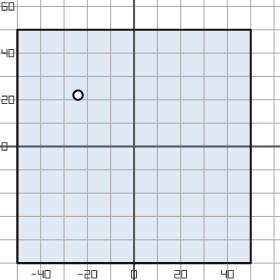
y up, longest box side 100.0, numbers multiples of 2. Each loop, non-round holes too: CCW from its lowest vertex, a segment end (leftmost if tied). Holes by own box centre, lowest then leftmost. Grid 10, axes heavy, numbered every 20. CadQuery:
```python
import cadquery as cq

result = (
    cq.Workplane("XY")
    .moveTo(-50.0, -50.0)
    .lineTo(50.0, -50.0)
    .lineTo(50.0, 50.0)
    .lineTo(-50.0, 50.0)
    .close()
    .moveTo(-24.0, 22.0)
    .circle(2.0)
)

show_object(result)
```